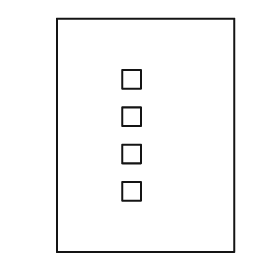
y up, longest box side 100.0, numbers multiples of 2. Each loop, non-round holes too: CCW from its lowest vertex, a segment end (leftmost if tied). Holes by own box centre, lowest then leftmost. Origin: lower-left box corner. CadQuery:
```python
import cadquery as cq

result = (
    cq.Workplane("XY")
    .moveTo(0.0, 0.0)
    .lineTo(76.0, 0.0)
    .lineTo(76.0, 100.0)
    .lineTo(0.0, 100.0)
    .close()
    .moveTo(28.0, 22.0)
    .lineTo(36.0, 22.0)
    .lineTo(36.0, 30.0)
    .lineTo(28.0, 30.0)
    .close()
    .moveTo(28.0, 38.0)
    .lineTo(36.0, 38.0)
    .lineTo(36.0, 46.0)
    .lineTo(28.0, 46.0)
    .close()
    .moveTo(28.0, 54.0)
    .lineTo(36.0, 54.0)
    .lineTo(36.0, 62.0)
    .lineTo(28.0, 62.0)
    .close()
    .moveTo(28.0, 70.0)
    .lineTo(36.0, 70.0)
    .lineTo(36.0, 78.0)
    .lineTo(28.0, 78.0)
    .close()
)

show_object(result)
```